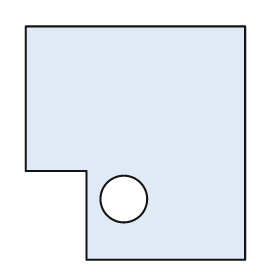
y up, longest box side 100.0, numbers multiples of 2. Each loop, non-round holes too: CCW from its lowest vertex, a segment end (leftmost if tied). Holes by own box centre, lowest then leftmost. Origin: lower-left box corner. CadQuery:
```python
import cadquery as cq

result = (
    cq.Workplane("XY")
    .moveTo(26.0, 0.0)
    .lineTo(94.0, 0.0)
    .lineTo(94.0, 100.0)
    .lineTo(0.0, 100.0)
    .lineTo(0.0, 38.0)
    .lineTo(26.0, 38.0)
    .close()
    .moveTo(42.0, 26.0)
    .circle(10.0)
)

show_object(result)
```